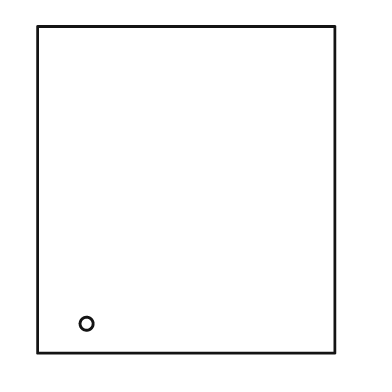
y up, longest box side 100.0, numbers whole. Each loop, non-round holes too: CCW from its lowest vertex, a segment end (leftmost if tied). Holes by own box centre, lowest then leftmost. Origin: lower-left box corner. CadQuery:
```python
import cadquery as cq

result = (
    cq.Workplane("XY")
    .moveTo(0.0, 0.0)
    .lineTo(91.0, 0.0)
    .lineTo(91.0, 100.0)
    .lineTo(0.0, 100.0)
    .close()
    .moveTo(15.0, 9.0)
    .circle(2.0)
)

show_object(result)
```